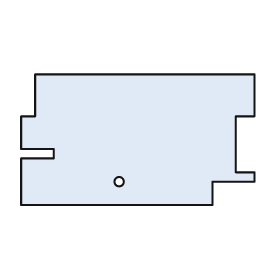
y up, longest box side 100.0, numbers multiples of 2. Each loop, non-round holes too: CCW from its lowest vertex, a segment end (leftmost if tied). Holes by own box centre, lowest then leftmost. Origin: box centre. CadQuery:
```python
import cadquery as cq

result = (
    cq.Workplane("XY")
    .moveTo(-50.0, -28.0)
    .lineTo(32.0, -28.0)
    .lineTo(32.0, -18.0)
    .lineTo(50.0, -18.0)
    .lineTo(50.0, -14.0)
    .lineTo(42.0, -14.0)
    .lineTo(42.0, 10.0)
    .lineTo(50.0, 10.0)
    .lineTo(50.0, 28.0)
    .lineTo(-44.0, 28.0)
    .lineTo(-44.0, 10.0)
    .lineTo(-50.0, 10.0)
    .lineTo(-50.0, -4.0)
    .lineTo(-36.0, -4.0)
    .lineTo(-36.0, -8.0)
    .lineTo(-50.0, -8.0)
    .close()
    .moveTo(-8.0, -18.0)
    .circle(2.0)
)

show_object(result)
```